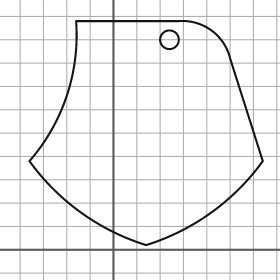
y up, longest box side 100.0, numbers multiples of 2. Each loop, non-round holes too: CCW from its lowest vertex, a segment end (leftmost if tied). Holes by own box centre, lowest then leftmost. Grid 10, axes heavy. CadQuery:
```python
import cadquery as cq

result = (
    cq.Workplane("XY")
    .moveTo(14.0, 2.0)
    .threePointArc((42.0, 16.0), (64.0, 38.0))
    .lineTo(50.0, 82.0)
    .threePointArc((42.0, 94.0), (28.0, 98.0))
    .lineTo(-16.0, 98.0)
    .threePointArc((-20.0, 66.0), (-36.0, 38.0))
    .threePointArc((-14.0, 16.0), (14.0, 2.0))
    .close()
    .moveTo(24.0, 90.0)
    .circle(4.0)
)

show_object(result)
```